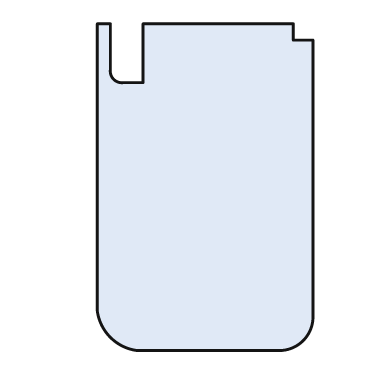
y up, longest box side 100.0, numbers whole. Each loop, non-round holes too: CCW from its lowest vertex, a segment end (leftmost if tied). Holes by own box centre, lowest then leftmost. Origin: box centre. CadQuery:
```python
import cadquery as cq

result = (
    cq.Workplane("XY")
    .moveTo(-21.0, -50.0)
    .lineTo(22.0, -50.0)
    .threePointArc((30.0, -47.0), (33.0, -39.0))
    .lineTo(33.0, 45.0)
    .lineTo(27.0, 45.0)
    .lineTo(27.0, 50.0)
    .lineTo(-19.0, 50.0)
    .lineTo(-19.0, 32.0)
    .lineTo(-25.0, 32.0)
    .threePointArc((-28.0, 33.0), (-29.0, 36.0))
    .lineTo(-29.0, 50.0)
    .lineTo(-33.0, 50.0)
    .lineTo(-33.0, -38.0)
    .threePointArc((-29.0, -46.0), (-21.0, -50.0))
    .close()
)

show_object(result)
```